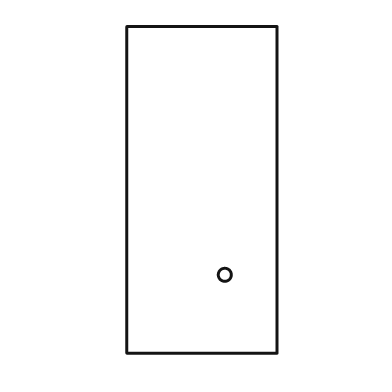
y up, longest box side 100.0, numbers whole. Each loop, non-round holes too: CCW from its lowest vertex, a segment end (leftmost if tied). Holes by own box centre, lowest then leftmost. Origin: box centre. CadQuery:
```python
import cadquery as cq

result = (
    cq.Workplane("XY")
    .moveTo(-23.0, -50.0)
    .lineTo(23.0, -50.0)
    .lineTo(23.0, 50.0)
    .lineTo(-23.0, 50.0)
    .close()
    .moveTo(7.0, -26.0)
    .circle(2.0)
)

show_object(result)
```